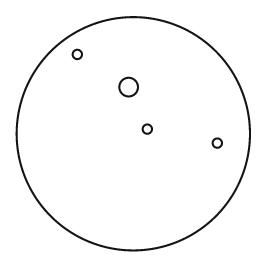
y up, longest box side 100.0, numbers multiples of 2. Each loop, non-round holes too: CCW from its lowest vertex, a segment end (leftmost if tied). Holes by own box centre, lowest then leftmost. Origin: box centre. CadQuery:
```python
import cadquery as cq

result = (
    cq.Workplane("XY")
    .moveTo(0.0, 0.0)
    .circle(50.0)
    .moveTo(36.0, -4.0)
    .circle(2.0)
    .moveTo(6.0, 2.0)
    .circle(2.0)
    .moveTo(-2.0, 20.0)
    .circle(4.0)
    .moveTo(-24.0, 34.0)
    .circle(2.0)
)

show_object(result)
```